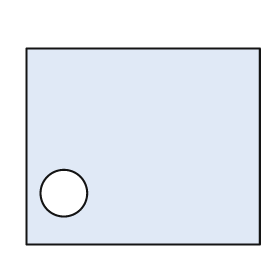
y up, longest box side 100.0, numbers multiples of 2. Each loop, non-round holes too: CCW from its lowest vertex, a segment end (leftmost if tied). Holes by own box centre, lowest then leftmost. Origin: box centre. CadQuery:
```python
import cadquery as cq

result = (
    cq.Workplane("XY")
    .moveTo(-50.0, -42.0)
    .lineTo(50.0, -42.0)
    .lineTo(50.0, 42.0)
    .lineTo(-50.0, 42.0)
    .close()
    .moveTo(-34.0, -20.0)
    .circle(10.0)
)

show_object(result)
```